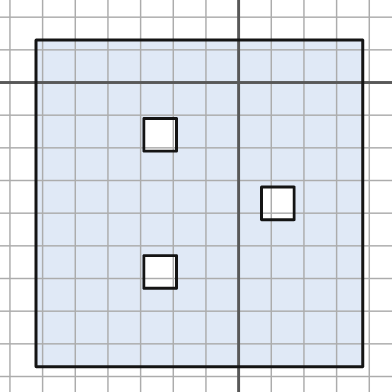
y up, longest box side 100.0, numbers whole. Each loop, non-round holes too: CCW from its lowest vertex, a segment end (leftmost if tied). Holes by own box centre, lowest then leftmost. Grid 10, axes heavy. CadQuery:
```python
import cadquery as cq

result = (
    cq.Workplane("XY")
    .moveTo(-62.0, -87.0)
    .lineTo(38.0, -87.0)
    .lineTo(38.0, 13.0)
    .lineTo(-62.0, 13.0)
    .close()
    .moveTo(-29.0, -63.0)
    .lineTo(-19.0, -63.0)
    .lineTo(-19.0, -53.0)
    .lineTo(-29.0, -53.0)
    .close()
    .moveTo(7.0, -42.0)
    .lineTo(17.0, -42.0)
    .lineTo(17.0, -32.0)
    .lineTo(7.0, -32.0)
    .close()
    .moveTo(-29.0, -21.0)
    .lineTo(-19.0, -21.0)
    .lineTo(-19.0, -11.0)
    .lineTo(-29.0, -11.0)
    .close()
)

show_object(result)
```